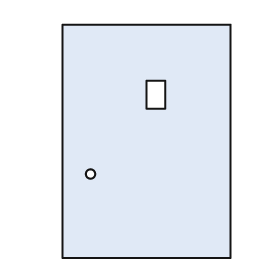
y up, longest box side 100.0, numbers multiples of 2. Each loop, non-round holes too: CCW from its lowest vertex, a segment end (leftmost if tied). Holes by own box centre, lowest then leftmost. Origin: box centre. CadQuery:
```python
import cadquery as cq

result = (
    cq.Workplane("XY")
    .moveTo(-36.0, -50.0)
    .lineTo(36.0, -50.0)
    .lineTo(36.0, 50.0)
    .lineTo(-36.0, 50.0)
    .close()
    .moveTo(-24.0, -14.0)
    .circle(2.0)
    .moveTo(0.0, 14.0)
    .lineTo(8.0, 14.0)
    .lineTo(8.0, 26.0)
    .lineTo(0.0, 26.0)
    .close()
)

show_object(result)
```